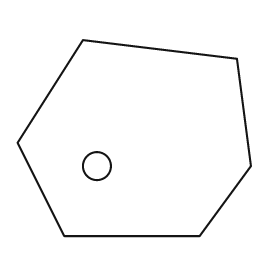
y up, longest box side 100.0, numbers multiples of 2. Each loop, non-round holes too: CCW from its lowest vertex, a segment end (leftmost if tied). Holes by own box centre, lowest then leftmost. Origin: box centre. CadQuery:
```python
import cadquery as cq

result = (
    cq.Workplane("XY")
    .moveTo(-30.0, -42.0)
    .lineTo(28.0, -42.0)
    .lineTo(50.0, -12.0)
    .lineTo(44.0, 34.0)
    .lineTo(-22.0, 42.0)
    .lineTo(-50.0, -2.0)
    .close()
    .moveTo(-16.0, -12.0)
    .circle(6.0)
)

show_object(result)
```